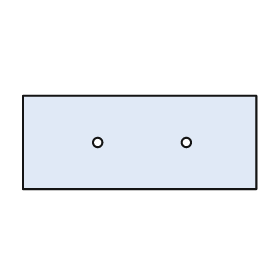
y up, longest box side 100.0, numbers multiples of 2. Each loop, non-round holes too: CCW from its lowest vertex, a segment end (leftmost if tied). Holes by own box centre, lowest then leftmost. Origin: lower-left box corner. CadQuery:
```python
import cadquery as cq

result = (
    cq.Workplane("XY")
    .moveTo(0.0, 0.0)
    .lineTo(100.0, 0.0)
    .lineTo(100.0, 40.0)
    .lineTo(0.0, 40.0)
    .close()
    .moveTo(32.0, 20.0)
    .circle(2.0)
    .moveTo(70.0, 20.0)
    .circle(2.0)
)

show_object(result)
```